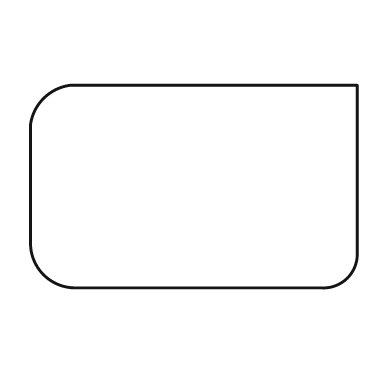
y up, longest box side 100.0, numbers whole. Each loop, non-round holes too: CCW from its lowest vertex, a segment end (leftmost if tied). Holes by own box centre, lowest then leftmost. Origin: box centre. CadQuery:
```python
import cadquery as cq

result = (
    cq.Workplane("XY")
    .moveTo(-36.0, -31.0)
    .lineTo(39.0, -31.0)
    .threePointArc((47.0, -28.0), (50.0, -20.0))
    .lineTo(50.0, 31.0)
    .lineTo(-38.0, 31.0)
    .threePointArc((-46.0, 27.0), (-50.0, 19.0))
    .lineTo(-50.0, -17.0)
    .threePointArc((-46.0, -27.0), (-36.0, -31.0))
    .close()
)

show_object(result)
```